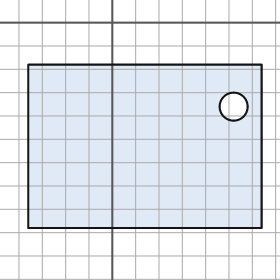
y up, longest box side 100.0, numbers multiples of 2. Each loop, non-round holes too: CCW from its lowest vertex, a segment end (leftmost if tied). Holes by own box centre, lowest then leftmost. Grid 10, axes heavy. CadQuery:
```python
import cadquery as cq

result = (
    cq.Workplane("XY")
    .moveTo(-36.0, -88.0)
    .lineTo(64.0, -88.0)
    .lineTo(64.0, -18.0)
    .lineTo(-36.0, -18.0)
    .close()
    .moveTo(52.0, -36.0)
    .circle(6.0)
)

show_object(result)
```